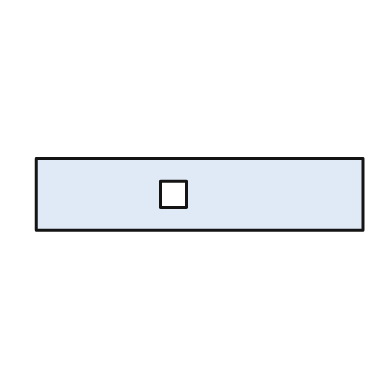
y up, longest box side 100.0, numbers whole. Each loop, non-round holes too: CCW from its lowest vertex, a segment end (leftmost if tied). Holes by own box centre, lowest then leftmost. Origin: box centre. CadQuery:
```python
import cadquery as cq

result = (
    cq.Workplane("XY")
    .moveTo(-50.0, -11.0)
    .lineTo(50.0, -11.0)
    .lineTo(50.0, 11.0)
    .lineTo(-50.0, 11.0)
    .close()
    .moveTo(-12.0, -4.0)
    .lineTo(-4.0, -4.0)
    .lineTo(-4.0, 4.0)
    .lineTo(-12.0, 4.0)
    .close()
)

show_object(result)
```